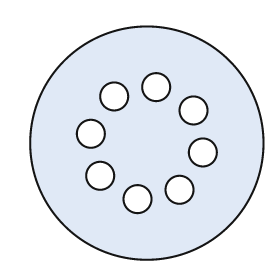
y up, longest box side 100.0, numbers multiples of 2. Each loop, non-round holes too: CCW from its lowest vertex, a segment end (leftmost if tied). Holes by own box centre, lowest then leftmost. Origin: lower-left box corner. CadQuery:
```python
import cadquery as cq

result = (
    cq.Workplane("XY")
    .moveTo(50.0, 50.0)
    .circle(50.0)
    .moveTo(46.0, 26.0)
    .circle(6.0)
    .moveTo(64.0, 30.0)
    .circle(6.0)
    .moveTo(30.0, 36.0)
    .circle(6.0)
    .moveTo(74.0, 46.0)
    .circle(6.0)
    .moveTo(26.0, 54.0)
    .circle(6.0)
    .moveTo(70.0, 64.0)
    .circle(6.0)
    .moveTo(36.0, 70.0)
    .circle(6.0)
    .moveTo(54.0, 74.0)
    .circle(6.0)
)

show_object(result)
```